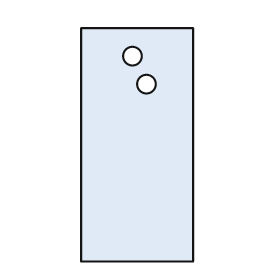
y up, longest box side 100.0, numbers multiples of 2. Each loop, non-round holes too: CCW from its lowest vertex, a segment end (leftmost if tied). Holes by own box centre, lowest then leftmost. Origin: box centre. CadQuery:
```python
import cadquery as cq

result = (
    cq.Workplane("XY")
    .moveTo(-24.0, -50.0)
    .lineTo(24.0, -50.0)
    .lineTo(24.0, 50.0)
    .lineTo(-24.0, 50.0)
    .close()
    .moveTo(4.0, 26.0)
    .circle(4.0)
    .moveTo(-2.0, 38.0)
    .circle(4.0)
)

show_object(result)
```